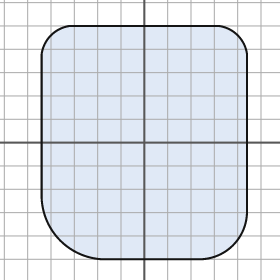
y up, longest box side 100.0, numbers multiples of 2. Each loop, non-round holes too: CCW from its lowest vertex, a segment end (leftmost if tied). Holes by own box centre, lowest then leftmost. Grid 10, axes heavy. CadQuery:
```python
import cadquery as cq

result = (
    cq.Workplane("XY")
    .moveTo(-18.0, -50.0)
    .lineTo(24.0, -50.0)
    .threePointArc((38.0, -44.0), (44.0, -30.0))
    .lineTo(44.0, 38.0)
    .threePointArc((40.0, 46.0), (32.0, 50.0))
    .lineTo(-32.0, 50.0)
    .threePointArc((-40.0, 46.0), (-44.0, 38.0))
    .lineTo(-44.0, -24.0)
    .threePointArc((-36.0, -42.0), (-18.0, -50.0))
    .close()
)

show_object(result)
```